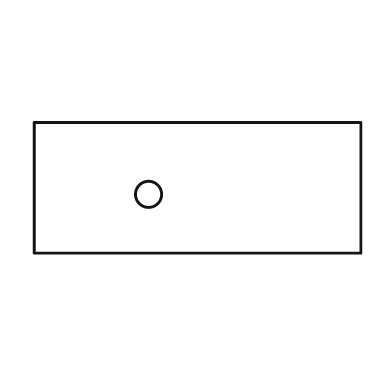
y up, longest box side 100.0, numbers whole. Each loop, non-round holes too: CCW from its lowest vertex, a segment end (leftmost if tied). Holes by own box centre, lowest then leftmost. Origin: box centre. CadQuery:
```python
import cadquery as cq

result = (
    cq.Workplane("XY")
    .moveTo(-50.0, -20.0)
    .lineTo(50.0, -20.0)
    .lineTo(50.0, 20.0)
    .lineTo(-50.0, 20.0)
    .close()
    .moveTo(-15.0, -2.0)
    .circle(4.0)
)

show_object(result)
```